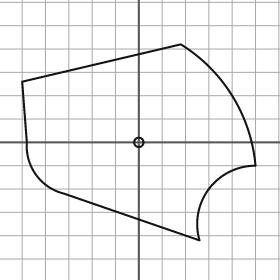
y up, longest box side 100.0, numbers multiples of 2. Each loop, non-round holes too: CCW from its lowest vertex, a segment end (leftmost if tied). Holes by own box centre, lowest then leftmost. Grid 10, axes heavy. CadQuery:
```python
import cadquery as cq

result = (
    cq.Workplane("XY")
    .moveTo(26.0, -42.0)
    .threePointArc((30.0, -20.0), (50.0, -10.0))
    .threePointArc((40.0, 20.0), (18.0, 42.0))
    .lineTo(-50.0, 26.0)
    .lineTo(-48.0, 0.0)
    .threePointArc((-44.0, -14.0), (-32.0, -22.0))
    .close()
    .moveTo(0.0, 0.0)
    .circle(2.0)
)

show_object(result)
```